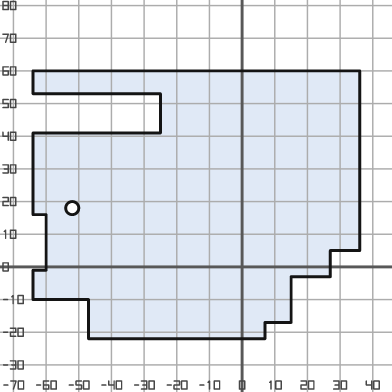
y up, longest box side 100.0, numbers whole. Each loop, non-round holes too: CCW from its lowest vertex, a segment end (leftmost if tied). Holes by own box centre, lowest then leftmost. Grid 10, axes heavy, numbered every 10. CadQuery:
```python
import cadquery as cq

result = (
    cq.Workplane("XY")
    .moveTo(-47.0, -22.0)
    .lineTo(7.0, -22.0)
    .lineTo(7.0, -17.0)
    .lineTo(15.0, -17.0)
    .lineTo(15.0, -3.0)
    .lineTo(27.0, -3.0)
    .lineTo(27.0, 5.0)
    .lineTo(36.0, 5.0)
    .lineTo(36.0, 60.0)
    .lineTo(-64.0, 60.0)
    .lineTo(-64.0, 53.0)
    .lineTo(-25.0, 53.0)
    .lineTo(-25.0, 41.0)
    .lineTo(-64.0, 41.0)
    .lineTo(-64.0, 16.0)
    .lineTo(-60.0, 16.0)
    .lineTo(-60.0, -1.0)
    .lineTo(-64.0, -1.0)
    .lineTo(-64.0, -10.0)
    .lineTo(-47.0, -10.0)
    .close()
    .moveTo(-52.0, 18.0)
    .circle(2.0)
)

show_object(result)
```